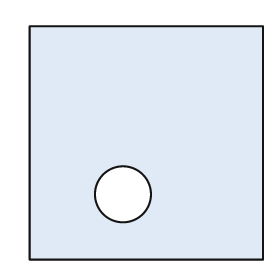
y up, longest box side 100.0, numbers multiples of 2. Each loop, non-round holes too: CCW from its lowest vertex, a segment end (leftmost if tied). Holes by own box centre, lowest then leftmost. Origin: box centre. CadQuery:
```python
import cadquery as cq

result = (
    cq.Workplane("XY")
    .moveTo(-50.0, -50.0)
    .lineTo(50.0, -50.0)
    .lineTo(50.0, 50.0)
    .lineTo(-50.0, 50.0)
    .close()
    .moveTo(-10.0, -22.0)
    .circle(12.0)
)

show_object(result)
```